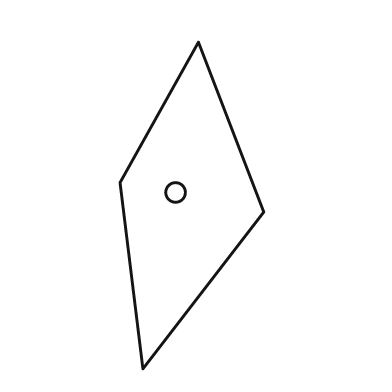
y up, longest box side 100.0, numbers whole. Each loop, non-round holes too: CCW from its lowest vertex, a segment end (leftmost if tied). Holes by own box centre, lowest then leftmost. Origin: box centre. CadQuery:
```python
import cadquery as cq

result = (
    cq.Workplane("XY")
    .moveTo(-15.0, -50.0)
    .lineTo(22.0, -2.0)
    .lineTo(2.0, 50.0)
    .lineTo(-22.0, 7.0)
    .close()
    .moveTo(-5.0, 4.0)
    .circle(3.0)
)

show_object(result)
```